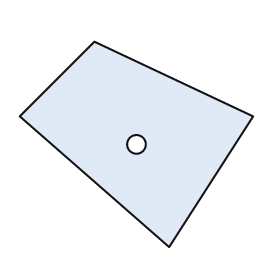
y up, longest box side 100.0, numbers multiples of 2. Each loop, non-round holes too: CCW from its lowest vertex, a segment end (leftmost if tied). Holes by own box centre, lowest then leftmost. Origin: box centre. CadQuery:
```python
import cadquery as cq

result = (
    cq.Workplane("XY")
    .moveTo(14.0, -44.0)
    .lineTo(50.0, 12.0)
    .lineTo(-18.0, 44.0)
    .lineTo(-50.0, 12.0)
    .close()
    .moveTo(0.0, 0.0)
    .circle(4.0)
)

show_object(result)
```